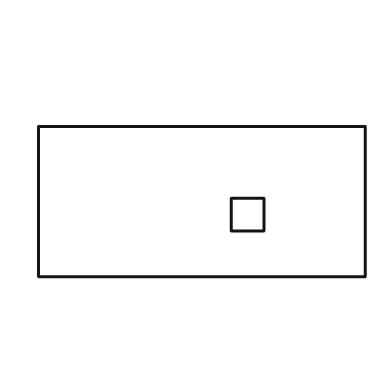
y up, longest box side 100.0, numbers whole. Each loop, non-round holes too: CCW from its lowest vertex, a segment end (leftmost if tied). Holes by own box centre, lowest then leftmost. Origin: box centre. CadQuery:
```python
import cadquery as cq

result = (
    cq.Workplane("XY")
    .moveTo(-50.0, -23.0)
    .lineTo(50.0, -23.0)
    .lineTo(50.0, 23.0)
    .lineTo(-50.0, 23.0)
    .close()
    .moveTo(9.0, -9.0)
    .lineTo(19.0, -9.0)
    .lineTo(19.0, 1.0)
    .lineTo(9.0, 1.0)
    .close()
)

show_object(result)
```